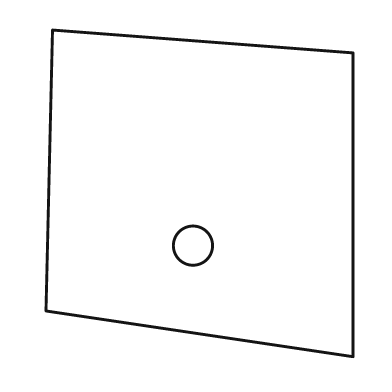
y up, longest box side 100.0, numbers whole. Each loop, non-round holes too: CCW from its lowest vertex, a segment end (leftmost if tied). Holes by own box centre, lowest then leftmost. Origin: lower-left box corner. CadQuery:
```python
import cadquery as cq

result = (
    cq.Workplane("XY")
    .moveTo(94.0, 0.0)
    .lineTo(94.0, 93.0)
    .lineTo(2.0, 100.0)
    .lineTo(0.0, 14.0)
    .close()
    .moveTo(45.0, 34.0)
    .circle(6.0)
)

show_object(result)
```